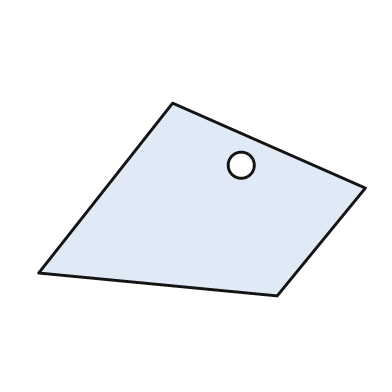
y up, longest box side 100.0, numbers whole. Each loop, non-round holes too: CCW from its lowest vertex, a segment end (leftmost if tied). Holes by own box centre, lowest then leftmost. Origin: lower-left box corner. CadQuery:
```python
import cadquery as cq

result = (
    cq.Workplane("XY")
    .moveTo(73.0, 0.0)
    .lineTo(100.0, 33.0)
    .lineTo(41.0, 59.0)
    .lineTo(0.0, 7.0)
    .close()
    .moveTo(62.0, 40.0)
    .circle(4.0)
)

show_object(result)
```